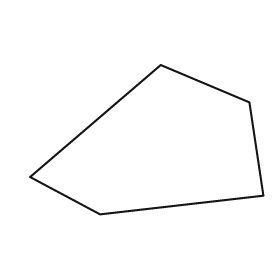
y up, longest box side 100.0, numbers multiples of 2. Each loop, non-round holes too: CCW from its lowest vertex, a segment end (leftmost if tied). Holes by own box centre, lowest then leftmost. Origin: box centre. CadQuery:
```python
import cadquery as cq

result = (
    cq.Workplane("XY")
    .moveTo(-20.0, -32.0)
    .lineTo(50.0, -24.0)
    .lineTo(44.0, 16.0)
    .lineTo(6.0, 32.0)
    .lineTo(-50.0, -16.0)
    .close()
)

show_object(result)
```